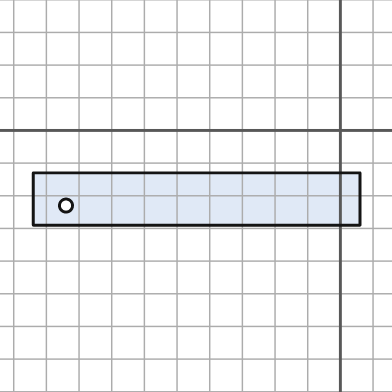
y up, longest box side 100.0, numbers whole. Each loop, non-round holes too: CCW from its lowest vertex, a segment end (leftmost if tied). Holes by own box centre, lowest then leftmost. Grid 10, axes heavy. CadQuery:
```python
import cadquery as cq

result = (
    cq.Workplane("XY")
    .moveTo(-94.0, -29.0)
    .lineTo(6.0, -29.0)
    .lineTo(6.0, -13.0)
    .lineTo(-94.0, -13.0)
    .close()
    .moveTo(-84.0, -23.0)
    .circle(2.0)
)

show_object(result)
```